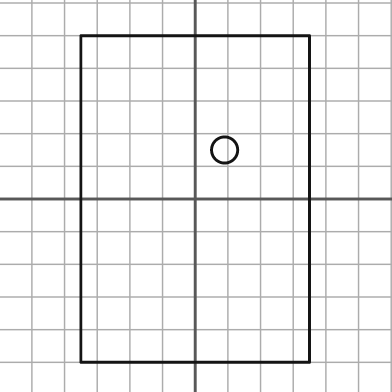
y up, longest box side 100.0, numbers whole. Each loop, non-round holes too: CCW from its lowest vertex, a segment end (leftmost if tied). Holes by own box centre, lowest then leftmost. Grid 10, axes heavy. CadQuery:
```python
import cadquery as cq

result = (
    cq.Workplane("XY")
    .moveTo(-35.0, -50.0)
    .lineTo(35.0, -50.0)
    .lineTo(35.0, 50.0)
    .lineTo(-35.0, 50.0)
    .close()
    .moveTo(9.0, 15.0)
    .circle(4.0)
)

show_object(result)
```